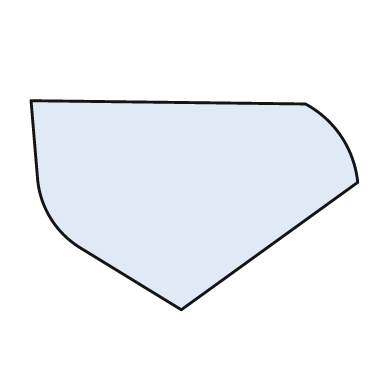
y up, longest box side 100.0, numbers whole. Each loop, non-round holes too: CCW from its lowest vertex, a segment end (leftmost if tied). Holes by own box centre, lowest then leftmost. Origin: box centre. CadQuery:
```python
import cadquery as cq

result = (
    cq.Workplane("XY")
    .moveTo(-4.0, -32.0)
    .lineTo(50.0, 7.0)
    .threePointArc((45.0, 21.0), (34.0, 31.0))
    .lineTo(-50.0, 32.0)
    .lineTo(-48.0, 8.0)
    .threePointArc((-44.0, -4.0), (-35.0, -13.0))
    .close()
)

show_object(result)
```